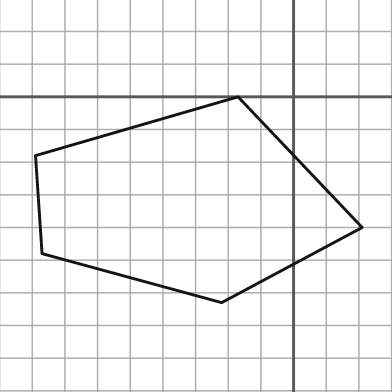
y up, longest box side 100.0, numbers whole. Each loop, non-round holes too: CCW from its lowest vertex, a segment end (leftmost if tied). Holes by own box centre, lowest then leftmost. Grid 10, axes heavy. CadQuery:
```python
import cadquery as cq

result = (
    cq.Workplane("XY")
    .moveTo(-22.0, -63.0)
    .lineTo(21.0, -40.0)
    .lineTo(-17.0, 0.0)
    .lineTo(-79.0, -18.0)
    .lineTo(-77.0, -48.0)
    .close()
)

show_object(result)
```